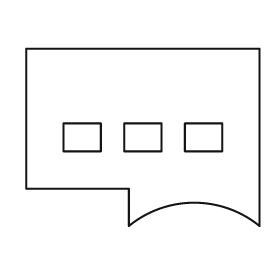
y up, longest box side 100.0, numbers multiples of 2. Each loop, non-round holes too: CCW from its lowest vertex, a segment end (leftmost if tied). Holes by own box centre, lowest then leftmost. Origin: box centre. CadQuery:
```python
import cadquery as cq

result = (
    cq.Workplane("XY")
    .moveTo(-6.0, -38.0)
    .threePointArc((22.0, -28.0), (50.0, -38.0))
    .lineTo(50.0, 38.0)
    .lineTo(-50.0, 38.0)
    .lineTo(-50.0, -22.0)
    .lineTo(-6.0, -22.0)
    .close()
    .moveTo(-34.0, -6.0)
    .lineTo(-18.0, -6.0)
    .lineTo(-18.0, 6.0)
    .lineTo(-34.0, 6.0)
    .close()
    .moveTo(-8.0, -6.0)
    .lineTo(8.0, -6.0)
    .lineTo(8.0, 6.0)
    .lineTo(-8.0, 6.0)
    .close()
    .moveTo(18.0, -6.0)
    .lineTo(34.0, -6.0)
    .lineTo(34.0, 6.0)
    .lineTo(18.0, 6.0)
    .close()
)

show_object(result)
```